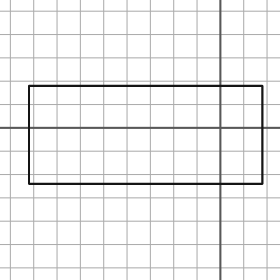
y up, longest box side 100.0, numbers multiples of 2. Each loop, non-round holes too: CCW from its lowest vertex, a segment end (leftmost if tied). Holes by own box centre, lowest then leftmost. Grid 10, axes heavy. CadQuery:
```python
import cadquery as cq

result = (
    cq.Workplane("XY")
    .moveTo(-82.0, -24.0)
    .lineTo(18.0, -24.0)
    .lineTo(18.0, 18.0)
    .lineTo(-82.0, 18.0)
    .close()
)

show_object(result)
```